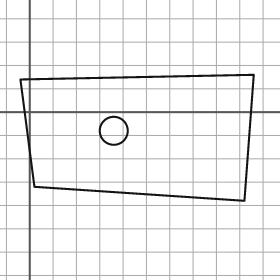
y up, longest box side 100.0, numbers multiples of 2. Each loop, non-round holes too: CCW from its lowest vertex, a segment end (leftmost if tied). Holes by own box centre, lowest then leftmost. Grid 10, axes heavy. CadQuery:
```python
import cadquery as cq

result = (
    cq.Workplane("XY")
    .moveTo(92.0, -38.0)
    .lineTo(96.0, 16.0)
    .lineTo(-4.0, 14.0)
    .lineTo(2.0, -32.0)
    .close()
    .moveTo(36.0, -8.0)
    .circle(6.0)
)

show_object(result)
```